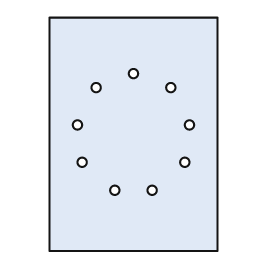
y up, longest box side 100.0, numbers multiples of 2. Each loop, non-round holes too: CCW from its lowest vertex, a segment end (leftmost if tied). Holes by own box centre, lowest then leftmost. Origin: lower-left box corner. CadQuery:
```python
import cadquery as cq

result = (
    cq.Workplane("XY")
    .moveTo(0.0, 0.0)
    .lineTo(72.0, 0.0)
    .lineTo(72.0, 100.0)
    .lineTo(0.0, 100.0)
    .close()
    .moveTo(28.0, 26.0)
    .circle(2.0)
    .moveTo(44.0, 26.0)
    .circle(2.0)
    .moveTo(14.0, 38.0)
    .circle(2.0)
    .moveTo(58.0, 38.0)
    .circle(2.0)
    .moveTo(12.0, 54.0)
    .circle(2.0)
    .moveTo(60.0, 54.0)
    .circle(2.0)
    .moveTo(20.0, 70.0)
    .circle(2.0)
    .moveTo(52.0, 70.0)
    .circle(2.0)
    .moveTo(36.0, 76.0)
    .circle(2.0)
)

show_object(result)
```